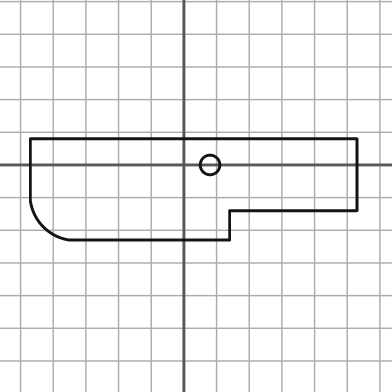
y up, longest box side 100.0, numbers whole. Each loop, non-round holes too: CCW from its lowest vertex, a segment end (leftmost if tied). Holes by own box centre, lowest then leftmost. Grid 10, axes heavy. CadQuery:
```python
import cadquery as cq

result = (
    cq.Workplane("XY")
    .moveTo(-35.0, -23.0)
    .lineTo(14.0, -23.0)
    .lineTo(14.0, -14.0)
    .lineTo(53.0, -14.0)
    .lineTo(53.0, 8.0)
    .lineTo(-47.0, 8.0)
    .lineTo(-47.0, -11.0)
    .threePointArc((-43.0, -19.0), (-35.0, -23.0))
    .close()
    .moveTo(8.0, 0.0)
    .circle(3.0)
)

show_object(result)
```